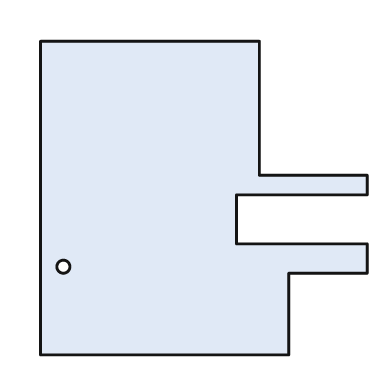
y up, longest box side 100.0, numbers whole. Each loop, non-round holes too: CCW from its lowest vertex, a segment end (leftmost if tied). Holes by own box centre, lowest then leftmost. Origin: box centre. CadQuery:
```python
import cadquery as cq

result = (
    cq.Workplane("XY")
    .moveTo(-50.0, -48.0)
    .lineTo(26.0, -48.0)
    .lineTo(26.0, -23.0)
    .lineTo(50.0, -23.0)
    .lineTo(50.0, -14.0)
    .lineTo(10.0, -14.0)
    .lineTo(10.0, 1.0)
    .lineTo(50.0, 1.0)
    .lineTo(50.0, 7.0)
    .lineTo(17.0, 7.0)
    .lineTo(17.0, 48.0)
    .lineTo(-50.0, 48.0)
    .close()
    .moveTo(-43.0, -21.0)
    .circle(2.0)
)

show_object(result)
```